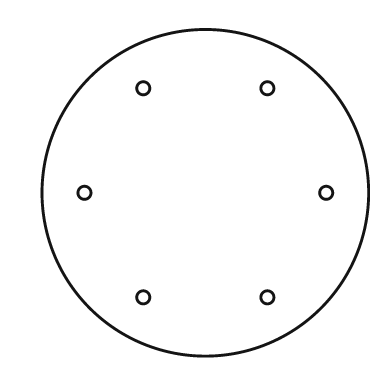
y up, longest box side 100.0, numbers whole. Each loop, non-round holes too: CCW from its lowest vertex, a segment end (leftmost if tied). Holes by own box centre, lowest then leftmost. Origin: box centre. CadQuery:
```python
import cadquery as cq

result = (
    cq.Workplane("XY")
    .moveTo(0.0, 0.0)
    .circle(50.0)
    .moveTo(-19.0, -32.0)
    .circle(2.0)
    .moveTo(19.0, -32.0)
    .circle(2.0)
    .moveTo(-37.0, 0.0)
    .circle(2.0)
    .moveTo(37.0, 0.0)
    .circle(2.0)
    .moveTo(-19.0, 32.0)
    .circle(2.0)
    .moveTo(19.0, 32.0)
    .circle(2.0)
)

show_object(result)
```